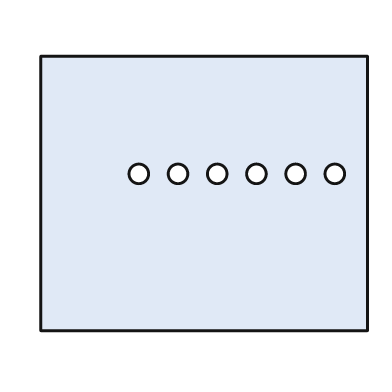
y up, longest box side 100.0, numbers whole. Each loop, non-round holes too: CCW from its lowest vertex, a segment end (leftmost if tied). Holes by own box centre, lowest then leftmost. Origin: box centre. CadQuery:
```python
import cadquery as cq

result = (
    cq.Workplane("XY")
    .moveTo(-50.0, -42.0)
    .lineTo(50.0, -42.0)
    .lineTo(50.0, 42.0)
    .lineTo(-50.0, 42.0)
    .close()
    .moveTo(-20.0, 6.0)
    .circle(3.0)
    .moveTo(-8.0, 6.0)
    .circle(3.0)
    .moveTo(4.0, 6.0)
    .circle(3.0)
    .moveTo(16.0, 6.0)
    .circle(3.0)
    .moveTo(28.0, 6.0)
    .circle(3.0)
    .moveTo(40.0, 6.0)
    .circle(3.0)
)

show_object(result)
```